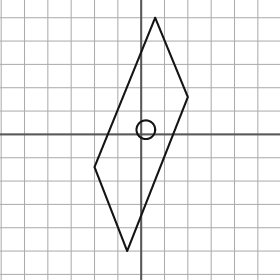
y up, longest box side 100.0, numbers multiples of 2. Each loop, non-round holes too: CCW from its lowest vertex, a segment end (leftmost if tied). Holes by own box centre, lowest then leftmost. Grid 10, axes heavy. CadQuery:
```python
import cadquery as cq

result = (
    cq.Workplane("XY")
    .moveTo(-6.0, -50.0)
    .lineTo(20.0, 16.0)
    .lineTo(6.0, 50.0)
    .lineTo(-20.0, -14.0)
    .close()
    .moveTo(2.0, 2.0)
    .circle(4.0)
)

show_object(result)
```